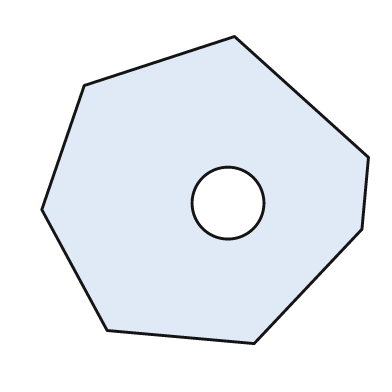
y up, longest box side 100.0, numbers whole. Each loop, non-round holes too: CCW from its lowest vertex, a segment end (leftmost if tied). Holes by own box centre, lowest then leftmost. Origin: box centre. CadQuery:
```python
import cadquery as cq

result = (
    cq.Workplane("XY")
    .moveTo(15.0, -47.0)
    .lineTo(48.0, -12.0)
    .lineTo(50.0, 10.0)
    .lineTo(9.0, 47.0)
    .lineTo(-37.0, 32.0)
    .lineTo(-50.0, -6.0)
    .lineTo(-30.0, -43.0)
    .close()
    .moveTo(7.0, -4.0)
    .circle(11.0)
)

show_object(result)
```